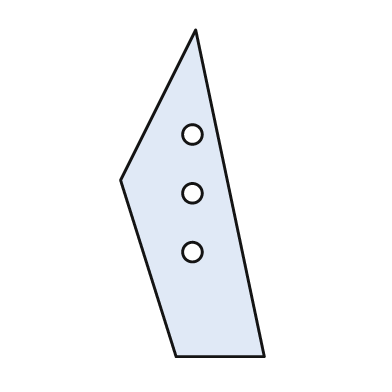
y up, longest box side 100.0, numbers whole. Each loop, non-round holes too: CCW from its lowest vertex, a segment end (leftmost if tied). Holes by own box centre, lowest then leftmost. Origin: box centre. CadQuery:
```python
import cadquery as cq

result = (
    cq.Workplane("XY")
    .moveTo(-5.0, -50.0)
    .lineTo(22.0, -50.0)
    .lineTo(1.0, 50.0)
    .lineTo(-22.0, 4.0)
    .close()
    .moveTo(0.0, -18.0)
    .circle(3.0)
    .moveTo(0.0, 0.0)
    .circle(3.0)
    .moveTo(0.0, 18.0)
    .circle(3.0)
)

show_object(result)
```